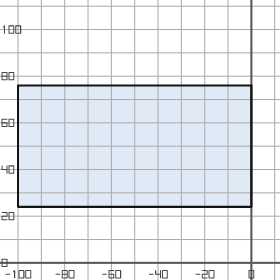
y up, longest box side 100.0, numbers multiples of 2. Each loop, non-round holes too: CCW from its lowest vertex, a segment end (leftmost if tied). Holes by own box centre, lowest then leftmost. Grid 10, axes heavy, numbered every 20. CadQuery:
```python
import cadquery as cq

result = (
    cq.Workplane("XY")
    .moveTo(-100.0, 24.0)
    .lineTo(0.0, 24.0)
    .lineTo(0.0, 76.0)
    .lineTo(-100.0, 76.0)
    .close()
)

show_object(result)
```